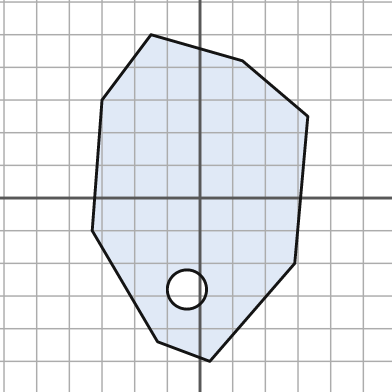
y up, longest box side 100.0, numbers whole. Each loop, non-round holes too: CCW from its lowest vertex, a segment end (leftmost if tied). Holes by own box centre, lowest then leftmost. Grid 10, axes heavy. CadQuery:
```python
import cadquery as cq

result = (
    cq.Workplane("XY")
    .moveTo(3.0, -50.0)
    .lineTo(29.0, -20.0)
    .lineTo(33.0, 25.0)
    .lineTo(13.0, 42.0)
    .lineTo(-15.0, 50.0)
    .lineTo(-30.0, 30.0)
    .lineTo(-33.0, -10.0)
    .lineTo(-13.0, -44.0)
    .close()
    .moveTo(-4.0, -28.0)
    .circle(6.0)
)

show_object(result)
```